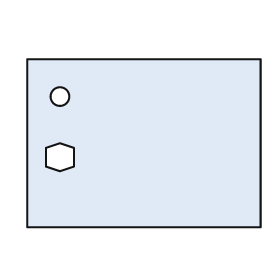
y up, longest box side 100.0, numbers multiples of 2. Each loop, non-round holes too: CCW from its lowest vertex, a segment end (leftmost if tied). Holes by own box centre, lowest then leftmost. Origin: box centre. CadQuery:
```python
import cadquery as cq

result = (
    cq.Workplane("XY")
    .moveTo(-50.0, -36.0)
    .lineTo(50.0, -36.0)
    .lineTo(50.0, 36.0)
    .lineTo(-50.0, 36.0)
    .close()
    .moveTo(-36.0, -12.0)
    .lineTo(-30.0, -10.0)
    .lineTo(-30.0, -2.0)
    .lineTo(-36.0, 0.0)
    .lineTo(-42.0, -2.0)
    .lineTo(-42.0, -10.0)
    .close()
    .moveTo(-36.0, 20.0)
    .circle(4.0)
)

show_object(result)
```